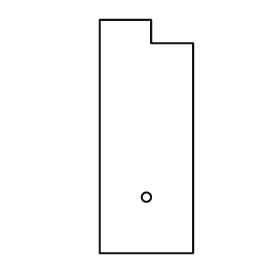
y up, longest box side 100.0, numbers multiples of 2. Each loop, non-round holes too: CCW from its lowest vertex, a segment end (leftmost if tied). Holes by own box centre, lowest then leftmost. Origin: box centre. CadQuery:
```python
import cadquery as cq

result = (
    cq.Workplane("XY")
    .moveTo(-20.0, -50.0)
    .lineTo(20.0, -50.0)
    .lineTo(20.0, 40.0)
    .lineTo(2.0, 40.0)
    .lineTo(2.0, 50.0)
    .lineTo(-20.0, 50.0)
    .close()
    .moveTo(0.0, -26.0)
    .circle(2.0)
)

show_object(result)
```